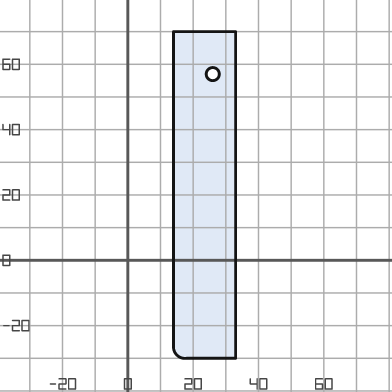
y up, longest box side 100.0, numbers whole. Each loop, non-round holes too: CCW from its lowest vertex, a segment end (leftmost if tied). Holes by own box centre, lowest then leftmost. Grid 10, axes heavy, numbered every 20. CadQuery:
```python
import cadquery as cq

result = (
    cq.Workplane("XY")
    .moveTo(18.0, -30.0)
    .lineTo(33.0, -30.0)
    .lineTo(33.0, 70.0)
    .lineTo(14.0, 70.0)
    .lineTo(14.0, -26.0)
    .threePointArc((15.0, -29.0), (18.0, -30.0))
    .close()
    .moveTo(26.0, 57.0)
    .circle(2.0)
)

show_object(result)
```